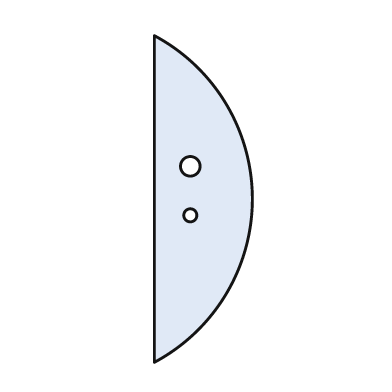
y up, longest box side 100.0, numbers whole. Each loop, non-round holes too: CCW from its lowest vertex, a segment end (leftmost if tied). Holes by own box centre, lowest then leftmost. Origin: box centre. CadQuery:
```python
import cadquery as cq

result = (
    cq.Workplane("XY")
    .moveTo(-15.0, -50.0)
    .threePointArc((15.0, 0.0), (-15.0, 50.0))
    .close()
    .moveTo(-4.0, -5.0)
    .circle(2.0)
    .moveTo(-4.0, 10.0)
    .circle(3.0)
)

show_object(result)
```